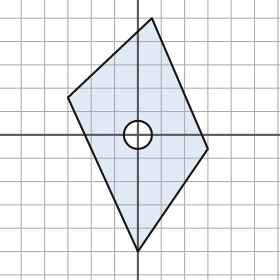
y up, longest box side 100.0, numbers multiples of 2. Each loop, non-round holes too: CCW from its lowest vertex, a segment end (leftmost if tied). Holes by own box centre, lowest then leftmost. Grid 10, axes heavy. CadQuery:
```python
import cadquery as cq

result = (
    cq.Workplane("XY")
    .moveTo(0.0, -50.0)
    .lineTo(30.0, -6.0)
    .lineTo(6.0, 50.0)
    .lineTo(-30.0, 16.0)
    .close()
    .moveTo(0.0, 0.0)
    .circle(6.0)
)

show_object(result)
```